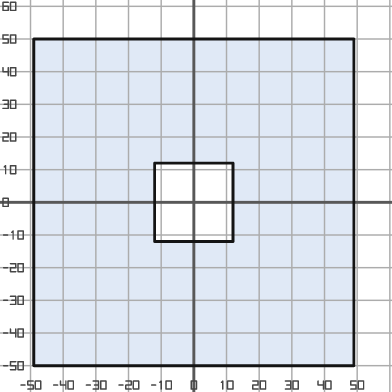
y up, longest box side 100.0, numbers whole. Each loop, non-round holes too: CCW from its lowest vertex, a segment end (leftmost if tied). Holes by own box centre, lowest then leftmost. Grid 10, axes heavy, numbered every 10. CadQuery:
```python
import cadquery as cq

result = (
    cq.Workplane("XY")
    .moveTo(-49.0, -50.0)
    .lineTo(49.0, -50.0)
    .lineTo(49.0, 50.0)
    .lineTo(-49.0, 50.0)
    .close()
    .moveTo(-12.0, -12.0)
    .lineTo(12.0, -12.0)
    .lineTo(12.0, 12.0)
    .lineTo(-12.0, 12.0)
    .close()
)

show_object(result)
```